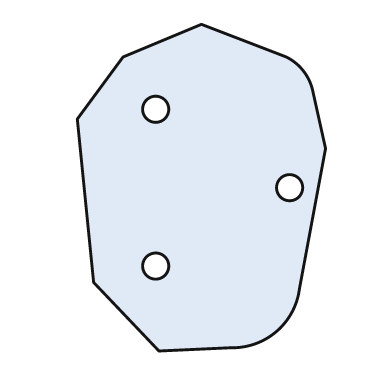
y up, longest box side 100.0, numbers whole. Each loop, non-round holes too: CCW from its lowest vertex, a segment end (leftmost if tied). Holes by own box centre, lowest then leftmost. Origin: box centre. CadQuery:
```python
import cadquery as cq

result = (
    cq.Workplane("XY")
    .moveTo(-13.0, -50.0)
    .lineTo(9.0, -49.0)
    .threePointArc((23.0, -44.0), (30.0, -31.0))
    .lineTo(38.0, 12.0)
    .lineTo(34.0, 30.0)
    .threePointArc((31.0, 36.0), (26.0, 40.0))
    .lineTo(0.0, 50.0)
    .lineTo(-24.0, 40.0)
    .lineTo(-38.0, 21.0)
    .lineTo(-33.0, -29.0)
    .close()
    .moveTo(-14.0, -24.0)
    .circle(4.0)
    .moveTo(27.0, 0.0)
    .circle(4.0)
    .moveTo(-14.0, 24.0)
    .circle(4.0)
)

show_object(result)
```